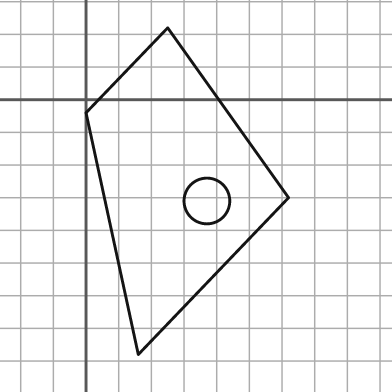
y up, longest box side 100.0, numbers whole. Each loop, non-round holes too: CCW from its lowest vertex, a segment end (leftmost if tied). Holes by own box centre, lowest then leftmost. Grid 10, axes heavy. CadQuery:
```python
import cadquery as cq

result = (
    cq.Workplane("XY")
    .moveTo(16.0, -78.0)
    .lineTo(62.0, -30.0)
    .lineTo(25.0, 22.0)
    .lineTo(0.0, -4.0)
    .close()
    .moveTo(37.0, -31.0)
    .circle(7.0)
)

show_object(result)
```